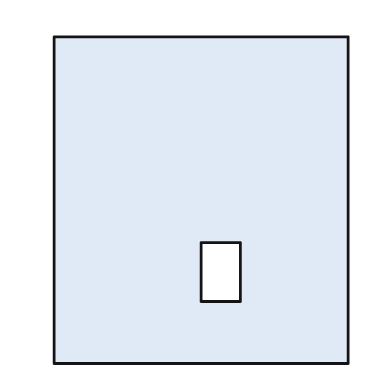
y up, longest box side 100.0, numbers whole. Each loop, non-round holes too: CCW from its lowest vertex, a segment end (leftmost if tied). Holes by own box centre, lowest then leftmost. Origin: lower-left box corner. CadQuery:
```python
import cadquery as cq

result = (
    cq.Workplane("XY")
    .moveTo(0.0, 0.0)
    .lineTo(90.0, 0.0)
    .lineTo(90.0, 100.0)
    .lineTo(0.0, 100.0)
    .close()
    .moveTo(45.0, 19.0)
    .lineTo(57.0, 19.0)
    .lineTo(57.0, 37.0)
    .lineTo(45.0, 37.0)
    .close()
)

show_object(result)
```